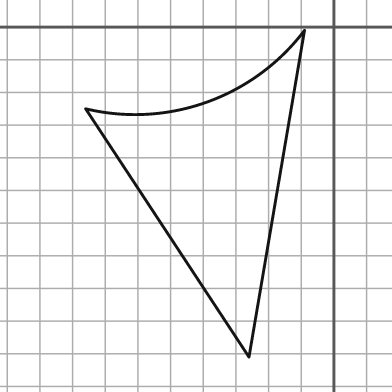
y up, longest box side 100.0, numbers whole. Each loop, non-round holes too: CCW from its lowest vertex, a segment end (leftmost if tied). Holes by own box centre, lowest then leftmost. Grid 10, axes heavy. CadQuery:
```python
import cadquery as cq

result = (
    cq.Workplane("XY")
    .moveTo(-26.0, -101.0)
    .lineTo(-9.0, -1.0)
    .threePointArc((-39.0, -23.0), (-76.0, -25.0))
    .close()
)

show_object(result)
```